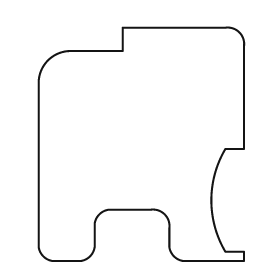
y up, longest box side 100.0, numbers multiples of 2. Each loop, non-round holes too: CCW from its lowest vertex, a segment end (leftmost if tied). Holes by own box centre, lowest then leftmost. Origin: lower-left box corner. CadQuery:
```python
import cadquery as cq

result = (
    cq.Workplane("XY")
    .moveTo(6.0, 0.0)
    .lineTo(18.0, 0.0)
    .threePointArc((22.0, 2.0), (24.0, 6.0))
    .lineTo(24.0, 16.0)
    .threePointArc((26.0, 20.0), (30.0, 22.0))
    .lineTo(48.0, 22.0)
    .threePointArc((54.0, 20.0), (56.0, 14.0))
    .lineTo(56.0, 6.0)
    .threePointArc((58.0, 2.0), (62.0, 0.0))
    .lineTo(88.0, 0.0)
    .lineTo(88.0, 4.0)
    .lineTo(80.0, 4.0)
    .threePointArc((74.0, 26.0), (80.0, 48.0))
    .lineTo(88.0, 48.0)
    .lineTo(88.0, 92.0)
    .threePointArc((86.0, 98.0), (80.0, 100.0))
    .lineTo(36.0, 100.0)
    .lineTo(36.0, 90.0)
    .lineTo(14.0, 90.0)
    .threePointArc((4.0, 86.0), (0.0, 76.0))
    .lineTo(0.0, 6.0)
    .threePointArc((2.0, 2.0), (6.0, 0.0))
    .close()
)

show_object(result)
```